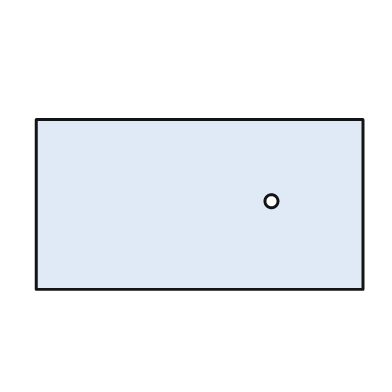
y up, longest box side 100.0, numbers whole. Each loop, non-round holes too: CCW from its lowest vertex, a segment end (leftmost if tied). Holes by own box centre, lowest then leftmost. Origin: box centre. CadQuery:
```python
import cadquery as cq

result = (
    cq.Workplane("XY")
    .moveTo(-50.0, -26.0)
    .lineTo(50.0, -26.0)
    .lineTo(50.0, 26.0)
    .lineTo(-50.0, 26.0)
    .close()
    .moveTo(22.0, 1.0)
    .circle(2.0)
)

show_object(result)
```